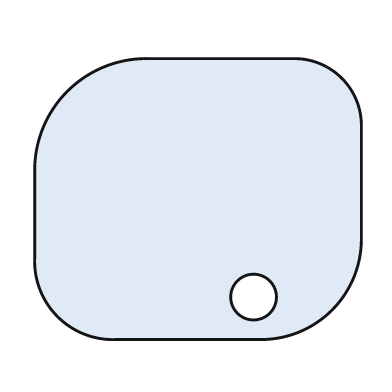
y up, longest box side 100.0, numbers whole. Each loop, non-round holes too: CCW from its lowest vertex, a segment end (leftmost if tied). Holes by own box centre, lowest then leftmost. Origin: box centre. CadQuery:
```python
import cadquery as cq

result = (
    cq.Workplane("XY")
    .moveTo(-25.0, -43.0)
    .lineTo(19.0, -43.0)
    .threePointArc((41.0, -34.0), (50.0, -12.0))
    .lineTo(50.0, 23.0)
    .threePointArc((44.0, 37.0), (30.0, 43.0))
    .lineTo(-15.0, 43.0)
    .threePointArc((-40.0, 33.0), (-50.0, 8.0))
    .lineTo(-50.0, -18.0)
    .threePointArc((-43.0, -36.0), (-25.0, -43.0))
    .close()
    .moveTo(17.0, -30.0)
    .circle(7.0)
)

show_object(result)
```